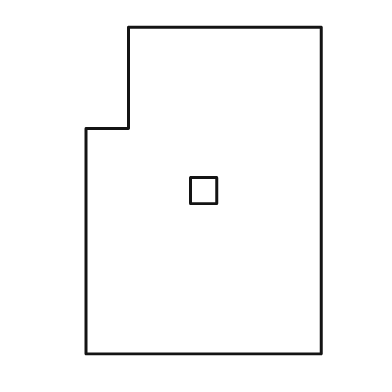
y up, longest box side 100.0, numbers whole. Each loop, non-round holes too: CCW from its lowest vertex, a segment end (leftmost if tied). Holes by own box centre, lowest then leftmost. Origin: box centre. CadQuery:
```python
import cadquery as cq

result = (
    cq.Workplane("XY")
    .moveTo(-36.0, -50.0)
    .lineTo(36.0, -50.0)
    .lineTo(36.0, 50.0)
    .lineTo(-23.0, 50.0)
    .lineTo(-23.0, 19.0)
    .lineTo(-36.0, 19.0)
    .close()
    .moveTo(-4.0, -4.0)
    .lineTo(4.0, -4.0)
    .lineTo(4.0, 4.0)
    .lineTo(-4.0, 4.0)
    .close()
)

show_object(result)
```